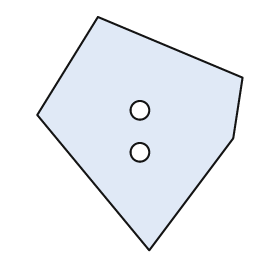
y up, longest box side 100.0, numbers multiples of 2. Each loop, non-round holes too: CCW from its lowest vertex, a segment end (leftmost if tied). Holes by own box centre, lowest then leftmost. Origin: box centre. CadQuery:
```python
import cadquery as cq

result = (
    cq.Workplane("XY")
    .moveTo(4.0, -50.0)
    .lineTo(40.0, -2.0)
    .lineTo(44.0, 24.0)
    .lineTo(-18.0, 50.0)
    .lineTo(-44.0, 8.0)
    .close()
    .moveTo(0.0, -8.0)
    .circle(4.0)
    .moveTo(0.0, 10.0)
    .circle(4.0)
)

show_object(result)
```